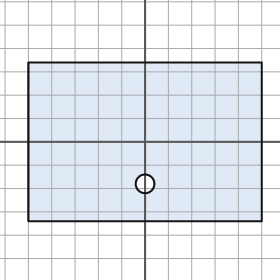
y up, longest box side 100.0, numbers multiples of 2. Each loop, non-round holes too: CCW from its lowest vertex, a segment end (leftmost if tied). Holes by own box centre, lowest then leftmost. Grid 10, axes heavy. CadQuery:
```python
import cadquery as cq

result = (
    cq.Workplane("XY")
    .moveTo(-50.0, -34.0)
    .lineTo(50.0, -34.0)
    .lineTo(50.0, 34.0)
    .lineTo(-50.0, 34.0)
    .close()
    .moveTo(0.0, -18.0)
    .circle(4.0)
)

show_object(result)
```